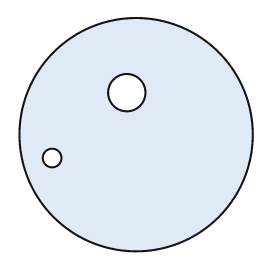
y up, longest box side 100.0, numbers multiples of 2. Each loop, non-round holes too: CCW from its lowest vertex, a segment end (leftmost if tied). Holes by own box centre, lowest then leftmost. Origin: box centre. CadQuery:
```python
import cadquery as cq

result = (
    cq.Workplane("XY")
    .moveTo(0.0, 0.0)
    .circle(50.0)
    .moveTo(-36.0, -10.0)
    .circle(4.0)
    .moveTo(-4.0, 18.0)
    .circle(8.0)
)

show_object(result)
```